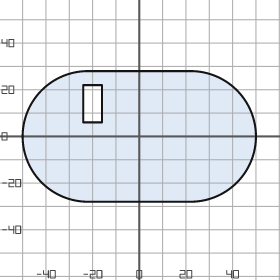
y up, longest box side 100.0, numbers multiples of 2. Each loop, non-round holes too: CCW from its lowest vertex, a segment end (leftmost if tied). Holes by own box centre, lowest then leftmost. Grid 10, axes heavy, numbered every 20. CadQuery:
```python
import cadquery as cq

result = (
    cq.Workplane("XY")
    .moveTo(-22.0, -28.0)
    .lineTo(22.0, -28.0)
    .threePointArc((50.0, 0.0), (22.0, 28.0))
    .lineTo(-22.0, 28.0)
    .threePointArc((-50.0, 0.0), (-22.0, -28.0))
    .close()
    .moveTo(-24.0, 6.0)
    .lineTo(-16.0, 6.0)
    .lineTo(-16.0, 22.0)
    .lineTo(-24.0, 22.0)
    .close()
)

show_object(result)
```